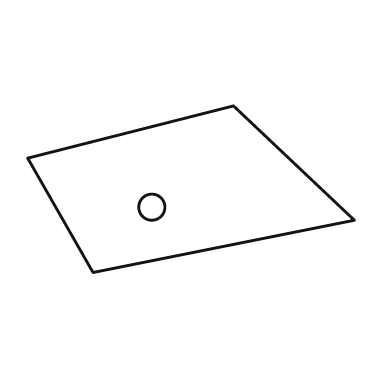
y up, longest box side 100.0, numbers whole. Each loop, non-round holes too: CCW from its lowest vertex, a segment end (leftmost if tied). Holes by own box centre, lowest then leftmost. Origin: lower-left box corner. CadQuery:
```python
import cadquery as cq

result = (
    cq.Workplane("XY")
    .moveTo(20.0, 0.0)
    .lineTo(100.0, 16.0)
    .lineTo(63.0, 51.0)
    .lineTo(0.0, 35.0)
    .close()
    .moveTo(38.0, 20.0)
    .circle(4.0)
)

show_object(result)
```